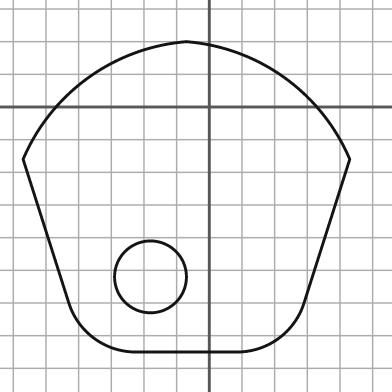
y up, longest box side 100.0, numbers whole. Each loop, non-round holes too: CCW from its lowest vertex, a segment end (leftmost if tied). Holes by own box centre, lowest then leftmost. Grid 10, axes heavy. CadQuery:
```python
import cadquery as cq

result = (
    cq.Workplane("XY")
    .moveTo(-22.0, -75.0)
    .lineTo(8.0, -75.0)
    .threePointArc((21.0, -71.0), (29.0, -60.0))
    .lineTo(43.0, -16.0)
    .threePointArc((23.0, 9.0), (-7.0, 20.0))
    .threePointArc((-37.0, 9.0), (-57.0, -16.0))
    .lineTo(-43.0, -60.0)
    .threePointArc((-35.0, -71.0), (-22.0, -75.0))
    .close()
    .moveTo(-18.0, -52.0)
    .circle(11.0)
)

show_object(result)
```